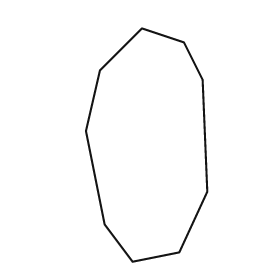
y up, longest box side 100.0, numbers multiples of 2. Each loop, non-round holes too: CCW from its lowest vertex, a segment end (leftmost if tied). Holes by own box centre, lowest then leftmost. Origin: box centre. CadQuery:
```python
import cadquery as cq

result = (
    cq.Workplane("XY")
    .moveTo(-6.0, -50.0)
    .lineTo(14.0, -46.0)
    .lineTo(26.0, -20.0)
    .lineTo(24.0, 28.0)
    .lineTo(16.0, 44.0)
    .lineTo(-2.0, 50.0)
    .lineTo(-20.0, 32.0)
    .lineTo(-26.0, 6.0)
    .lineTo(-18.0, -34.0)
    .close()
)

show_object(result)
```